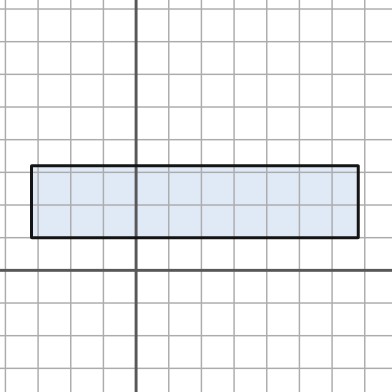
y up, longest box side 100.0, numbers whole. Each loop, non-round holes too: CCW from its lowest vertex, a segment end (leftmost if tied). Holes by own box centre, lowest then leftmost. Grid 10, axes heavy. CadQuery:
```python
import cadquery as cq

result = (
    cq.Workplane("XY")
    .moveTo(-32.0, 10.0)
    .lineTo(68.0, 10.0)
    .lineTo(68.0, 32.0)
    .lineTo(-32.0, 32.0)
    .close()
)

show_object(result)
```